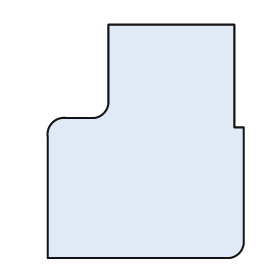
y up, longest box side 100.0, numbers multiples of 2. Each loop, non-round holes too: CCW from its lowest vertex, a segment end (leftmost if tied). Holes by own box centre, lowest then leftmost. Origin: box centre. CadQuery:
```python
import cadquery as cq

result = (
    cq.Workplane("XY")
    .moveTo(-42.0, -50.0)
    .lineTo(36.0, -50.0)
    .threePointArc((40.0, -48.0), (42.0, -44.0))
    .lineTo(42.0, 6.0)
    .lineTo(38.0, 6.0)
    .lineTo(38.0, 50.0)
    .lineTo(-16.0, 50.0)
    .lineTo(-16.0, 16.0)
    .threePointArc((-18.0, 12.0), (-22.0, 10.0))
    .lineTo(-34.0, 10.0)
    .threePointArc((-40.0, 8.0), (-42.0, 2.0))
    .close()
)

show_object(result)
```